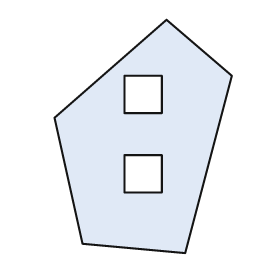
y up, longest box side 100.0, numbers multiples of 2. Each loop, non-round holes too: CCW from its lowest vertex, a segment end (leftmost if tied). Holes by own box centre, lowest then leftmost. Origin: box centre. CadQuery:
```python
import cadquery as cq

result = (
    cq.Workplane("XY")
    .moveTo(18.0, -50.0)
    .lineTo(38.0, 26.0)
    .lineTo(10.0, 50.0)
    .lineTo(-38.0, 8.0)
    .lineTo(-26.0, -46.0)
    .close()
    .moveTo(-8.0, -24.0)
    .lineTo(8.0, -24.0)
    .lineTo(8.0, -8.0)
    .lineTo(-8.0, -8.0)
    .close()
    .moveTo(-8.0, 10.0)
    .lineTo(8.0, 10.0)
    .lineTo(8.0, 26.0)
    .lineTo(-8.0, 26.0)
    .close()
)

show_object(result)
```